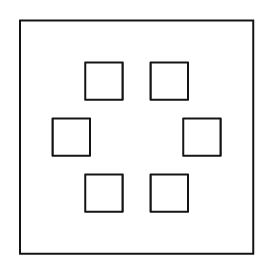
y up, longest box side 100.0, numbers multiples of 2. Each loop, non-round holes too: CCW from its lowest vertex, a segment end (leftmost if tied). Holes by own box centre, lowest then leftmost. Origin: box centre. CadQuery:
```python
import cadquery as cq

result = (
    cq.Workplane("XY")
    .moveTo(-50.0, -50.0)
    .lineTo(50.0, -50.0)
    .lineTo(50.0, 50.0)
    .lineTo(-50.0, 50.0)
    .close()
    .moveTo(-22.0, -32.0)
    .lineTo(-6.0, -32.0)
    .lineTo(-6.0, -16.0)
    .lineTo(-22.0, -16.0)
    .close()
    .moveTo(6.0, -32.0)
    .lineTo(22.0, -32.0)
    .lineTo(22.0, -16.0)
    .lineTo(6.0, -16.0)
    .close()
    .moveTo(-36.0, -8.0)
    .lineTo(-20.0, -8.0)
    .lineTo(-20.0, 8.0)
    .lineTo(-36.0, 8.0)
    .close()
    .moveTo(20.0, -8.0)
    .lineTo(36.0, -8.0)
    .lineTo(36.0, 8.0)
    .lineTo(20.0, 8.0)
    .close()
    .moveTo(-22.0, 16.0)
    .lineTo(-6.0, 16.0)
    .lineTo(-6.0, 32.0)
    .lineTo(-22.0, 32.0)
    .close()
    .moveTo(6.0, 16.0)
    .lineTo(22.0, 16.0)
    .lineTo(22.0, 32.0)
    .lineTo(6.0, 32.0)
    .close()
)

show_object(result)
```